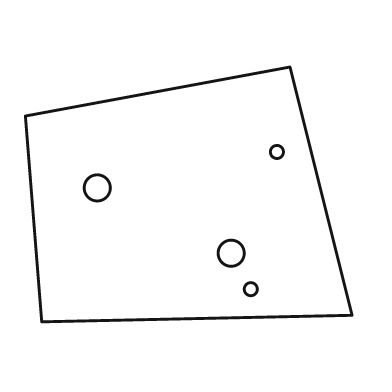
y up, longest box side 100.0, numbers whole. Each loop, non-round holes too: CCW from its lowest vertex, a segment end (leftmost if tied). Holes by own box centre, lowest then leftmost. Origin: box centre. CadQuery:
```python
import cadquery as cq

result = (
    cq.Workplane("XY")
    .moveTo(-45.0, -39.0)
    .lineTo(50.0, -37.0)
    .lineTo(31.0, 39.0)
    .lineTo(-50.0, 24.0)
    .close()
    .moveTo(19.0, -29.0)
    .circle(2.0)
    .moveTo(13.0, -18.0)
    .circle(4.0)
    .moveTo(-28.0, 2.0)
    .circle(4.0)
    .moveTo(27.0, 13.0)
    .circle(2.0)
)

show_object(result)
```